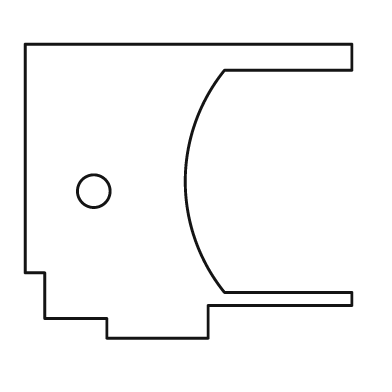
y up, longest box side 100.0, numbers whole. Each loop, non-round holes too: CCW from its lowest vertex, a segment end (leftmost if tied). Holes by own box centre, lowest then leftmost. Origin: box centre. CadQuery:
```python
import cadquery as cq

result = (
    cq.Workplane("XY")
    .moveTo(-25.0, -45.0)
    .lineTo(6.0, -45.0)
    .lineTo(6.0, -35.0)
    .lineTo(50.0, -35.0)
    .lineTo(50.0, -31.0)
    .lineTo(11.0, -31.0)
    .threePointArc((-1.0, 3.0), (11.0, 37.0))
    .lineTo(50.0, 37.0)
    .lineTo(50.0, 45.0)
    .lineTo(-50.0, 45.0)
    .lineTo(-50.0, -25.0)
    .lineTo(-44.0, -25.0)
    .lineTo(-44.0, -39.0)
    .lineTo(-25.0, -39.0)
    .close()
    .moveTo(-29.0, 0.0)
    .circle(5.0)
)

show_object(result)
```